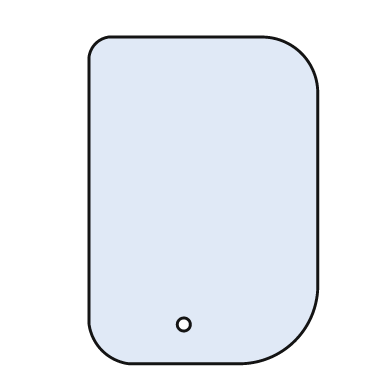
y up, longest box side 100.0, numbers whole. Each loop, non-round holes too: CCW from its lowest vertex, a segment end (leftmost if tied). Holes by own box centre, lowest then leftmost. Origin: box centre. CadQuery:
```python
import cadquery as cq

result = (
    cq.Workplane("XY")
    .moveTo(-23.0, -50.0)
    .lineTo(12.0, -50.0)
    .threePointArc((28.0, -43.0), (35.0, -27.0))
    .lineTo(35.0, 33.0)
    .threePointArc((30.0, 45.0), (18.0, 50.0))
    .lineTo(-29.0, 50.0)
    .threePointArc((-33.0, 48.0), (-35.0, 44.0))
    .lineTo(-35.0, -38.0)
    .threePointArc((-31.0, -46.0), (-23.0, -50.0))
    .close()
    .moveTo(-6.0, -38.0)
    .circle(2.0)
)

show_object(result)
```